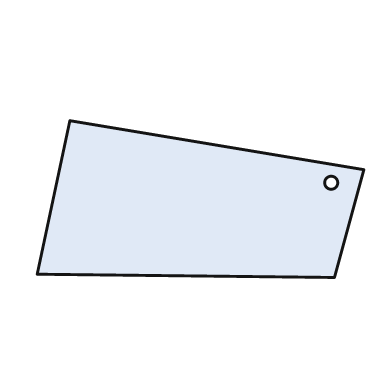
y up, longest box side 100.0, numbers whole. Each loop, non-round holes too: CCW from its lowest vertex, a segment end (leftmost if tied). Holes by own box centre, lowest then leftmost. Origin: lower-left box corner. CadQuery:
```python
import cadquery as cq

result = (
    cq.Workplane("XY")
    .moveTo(91.0, 0.0)
    .lineTo(100.0, 33.0)
    .lineTo(10.0, 48.0)
    .lineTo(0.0, 1.0)
    .close()
    .moveTo(90.0, 29.0)
    .circle(2.0)
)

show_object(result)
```